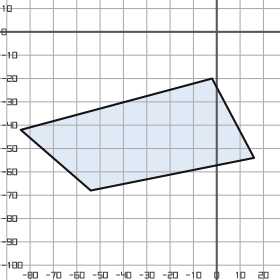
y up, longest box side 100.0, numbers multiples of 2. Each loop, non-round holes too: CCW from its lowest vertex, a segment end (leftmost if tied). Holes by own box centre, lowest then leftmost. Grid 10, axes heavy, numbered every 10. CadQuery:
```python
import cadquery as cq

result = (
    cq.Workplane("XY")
    .moveTo(-54.0, -68.0)
    .lineTo(16.0, -54.0)
    .lineTo(-2.0, -20.0)
    .lineTo(-84.0, -42.0)
    .close()
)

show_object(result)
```